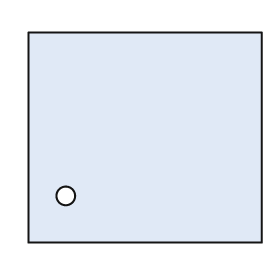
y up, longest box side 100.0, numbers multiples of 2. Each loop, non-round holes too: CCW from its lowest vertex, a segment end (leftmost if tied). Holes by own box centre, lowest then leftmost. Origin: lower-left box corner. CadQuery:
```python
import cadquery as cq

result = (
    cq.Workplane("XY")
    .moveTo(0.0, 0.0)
    .lineTo(100.0, 0.0)
    .lineTo(100.0, 90.0)
    .lineTo(0.0, 90.0)
    .close()
    .moveTo(16.0, 20.0)
    .circle(4.0)
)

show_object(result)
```